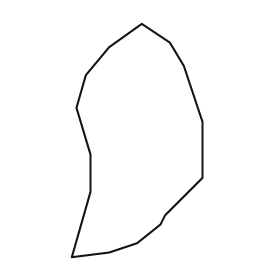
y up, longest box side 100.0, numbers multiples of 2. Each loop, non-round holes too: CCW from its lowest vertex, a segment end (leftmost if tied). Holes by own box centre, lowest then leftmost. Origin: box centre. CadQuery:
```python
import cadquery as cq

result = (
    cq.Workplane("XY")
    .moveTo(-28.0, -50.0)
    .lineTo(-12.0, -48.0)
    .lineTo(0.0, -44.0)
    .lineTo(10.0, -36.0)
    .lineTo(12.0, -32.0)
    .lineTo(28.0, -16.0)
    .lineTo(28.0, 8.0)
    .lineTo(20.0, 32.0)
    .lineTo(14.0, 42.0)
    .lineTo(2.0, 50.0)
    .lineTo(-12.0, 40.0)
    .lineTo(-22.0, 28.0)
    .lineTo(-26.0, 14.0)
    .lineTo(-20.0, -6.0)
    .lineTo(-20.0, -22.0)
    .close()
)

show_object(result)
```